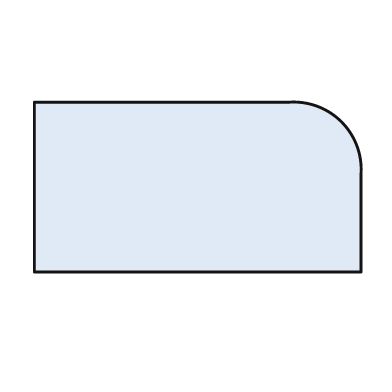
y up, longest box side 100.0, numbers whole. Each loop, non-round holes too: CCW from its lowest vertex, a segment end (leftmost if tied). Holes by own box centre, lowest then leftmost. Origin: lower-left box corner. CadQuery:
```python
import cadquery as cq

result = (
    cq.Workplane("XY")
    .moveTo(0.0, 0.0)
    .lineTo(100.0, 0.0)
    .lineTo(100.0, 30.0)
    .threePointArc((94.0, 46.0), (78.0, 52.0))
    .lineTo(0.0, 52.0)
    .close()
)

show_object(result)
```